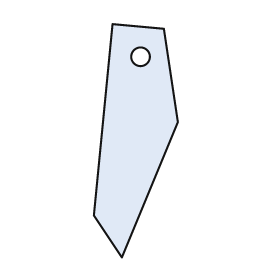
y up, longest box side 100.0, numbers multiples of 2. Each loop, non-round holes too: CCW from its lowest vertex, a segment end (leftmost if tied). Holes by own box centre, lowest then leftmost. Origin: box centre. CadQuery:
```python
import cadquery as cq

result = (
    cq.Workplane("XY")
    .moveTo(-6.0, -50.0)
    .lineTo(18.0, 8.0)
    .lineTo(12.0, 48.0)
    .lineTo(-10.0, 50.0)
    .lineTo(-18.0, -32.0)
    .close()
    .moveTo(2.0, 36.0)
    .circle(4.0)
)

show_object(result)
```